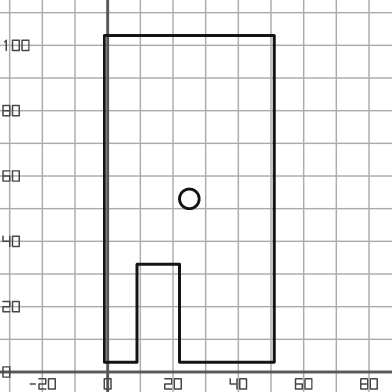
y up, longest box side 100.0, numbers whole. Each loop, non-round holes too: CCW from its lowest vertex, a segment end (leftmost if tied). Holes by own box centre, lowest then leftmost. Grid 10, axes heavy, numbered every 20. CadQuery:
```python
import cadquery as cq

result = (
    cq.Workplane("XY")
    .moveTo(-1.0, 3.0)
    .lineTo(9.0, 3.0)
    .lineTo(9.0, 33.0)
    .lineTo(22.0, 33.0)
    .lineTo(22.0, 3.0)
    .lineTo(51.0, 3.0)
    .lineTo(51.0, 103.0)
    .lineTo(-1.0, 103.0)
    .close()
    .moveTo(25.0, 53.0)
    .circle(3.0)
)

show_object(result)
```